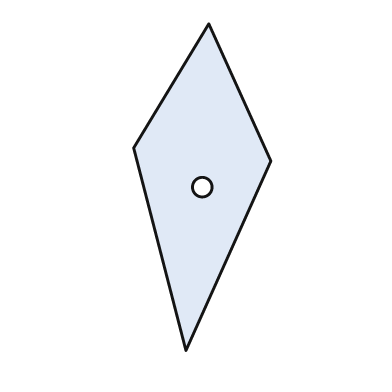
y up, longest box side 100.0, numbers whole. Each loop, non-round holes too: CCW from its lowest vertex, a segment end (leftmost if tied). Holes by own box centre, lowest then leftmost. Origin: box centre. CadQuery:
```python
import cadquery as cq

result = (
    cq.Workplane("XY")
    .moveTo(-5.0, -50.0)
    .lineTo(21.0, 8.0)
    .lineTo(2.0, 50.0)
    .lineTo(-21.0, 12.0)
    .close()
    .moveTo(0.0, 0.0)
    .circle(3.0)
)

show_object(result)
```